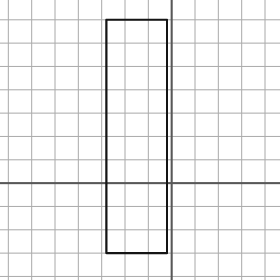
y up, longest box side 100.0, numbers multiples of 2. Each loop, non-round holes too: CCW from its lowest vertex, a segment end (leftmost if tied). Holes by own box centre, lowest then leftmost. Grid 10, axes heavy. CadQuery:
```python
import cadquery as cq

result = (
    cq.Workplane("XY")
    .moveTo(-28.0, -30.0)
    .lineTo(-2.0, -30.0)
    .lineTo(-2.0, 70.0)
    .lineTo(-28.0, 70.0)
    .close()
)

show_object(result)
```